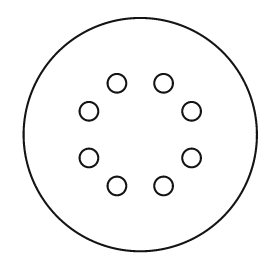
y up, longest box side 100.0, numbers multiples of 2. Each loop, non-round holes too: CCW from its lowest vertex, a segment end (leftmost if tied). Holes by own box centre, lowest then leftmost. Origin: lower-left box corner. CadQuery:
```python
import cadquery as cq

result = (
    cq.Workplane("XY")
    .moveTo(50.0, 50.0)
    .circle(50.0)
    .moveTo(40.0, 28.0)
    .circle(4.0)
    .moveTo(60.0, 28.0)
    .circle(4.0)
    .moveTo(28.0, 40.0)
    .circle(4.0)
    .moveTo(72.0, 40.0)
    .circle(4.0)
    .moveTo(28.0, 60.0)
    .circle(4.0)
    .moveTo(72.0, 60.0)
    .circle(4.0)
    .moveTo(40.0, 72.0)
    .circle(4.0)
    .moveTo(60.0, 72.0)
    .circle(4.0)
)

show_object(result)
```